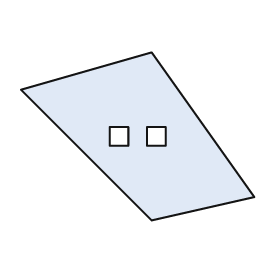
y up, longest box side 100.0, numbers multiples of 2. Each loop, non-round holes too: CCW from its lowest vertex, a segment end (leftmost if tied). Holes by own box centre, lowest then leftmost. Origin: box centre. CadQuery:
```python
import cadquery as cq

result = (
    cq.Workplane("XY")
    .moveTo(6.0, -36.0)
    .lineTo(50.0, -26.0)
    .lineTo(6.0, 36.0)
    .lineTo(-50.0, 20.0)
    .close()
    .moveTo(-12.0, -4.0)
    .lineTo(-4.0, -4.0)
    .lineTo(-4.0, 4.0)
    .lineTo(-12.0, 4.0)
    .close()
    .moveTo(4.0, -4.0)
    .lineTo(12.0, -4.0)
    .lineTo(12.0, 4.0)
    .lineTo(4.0, 4.0)
    .close()
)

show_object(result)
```